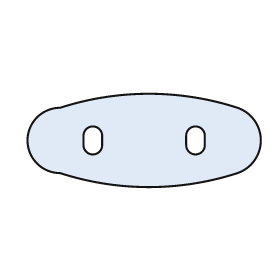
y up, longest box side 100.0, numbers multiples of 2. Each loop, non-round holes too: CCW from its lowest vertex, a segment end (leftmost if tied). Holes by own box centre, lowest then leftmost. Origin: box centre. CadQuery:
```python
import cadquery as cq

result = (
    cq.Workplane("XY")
    .moveTo(-36.0, -14.0)
    .threePointArc((2.0, -20.0), (40.0, -14.0))
    .threePointArc((50.0, 0.0), (40.0, 14.0))
    .threePointArc((2.0, 20.0), (-36.0, 14.0))
    .threePointArc((-50.0, 0.0), (-36.0, -14.0))
    .close()
    .moveTo(-26.0, -2.0)
    .threePointArc((-22.0, -6.0), (-18.0, -2.0))
    .lineTo(-18.0, 2.0)
    .threePointArc((-22.0, 6.0), (-26.0, 2.0))
    .close()
    .moveTo(18.0, -2.0)
    .threePointArc((22.0, -6.0), (26.0, -2.0))
    .lineTo(26.0, 2.0)
    .threePointArc((22.0, 6.0), (18.0, 2.0))
    .close()
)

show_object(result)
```